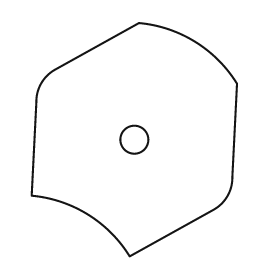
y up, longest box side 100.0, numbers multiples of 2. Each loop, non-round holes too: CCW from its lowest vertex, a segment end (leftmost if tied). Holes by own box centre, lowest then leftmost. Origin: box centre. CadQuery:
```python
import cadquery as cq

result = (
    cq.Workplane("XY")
    .moveTo(-2.0, -50.0)
    .lineTo(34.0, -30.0)
    .threePointArc((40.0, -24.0), (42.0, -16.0))
    .lineTo(44.0, 24.0)
    .threePointArc((26.0, 42.0), (2.0, 50.0))
    .lineTo(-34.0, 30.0)
    .threePointArc((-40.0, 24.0), (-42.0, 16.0))
    .lineTo(-44.0, -24.0)
    .threePointArc((-20.0, -32.0), (-2.0, -50.0))
    .close()
    .moveTo(0.0, 0.0)
    .circle(6.0)
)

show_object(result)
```